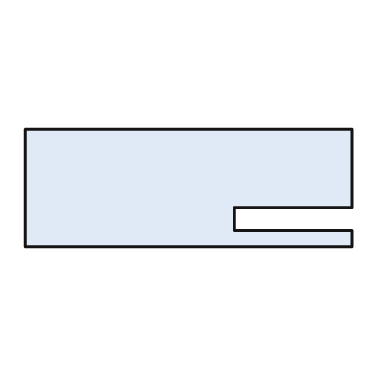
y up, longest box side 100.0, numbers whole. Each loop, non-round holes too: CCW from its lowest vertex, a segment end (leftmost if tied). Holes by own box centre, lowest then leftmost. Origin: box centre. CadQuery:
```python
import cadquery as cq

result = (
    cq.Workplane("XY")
    .moveTo(-50.0, -18.0)
    .lineTo(50.0, -18.0)
    .lineTo(50.0, -13.0)
    .lineTo(14.0, -13.0)
    .lineTo(14.0, -6.0)
    .lineTo(50.0, -6.0)
    .lineTo(50.0, 18.0)
    .lineTo(-50.0, 18.0)
    .close()
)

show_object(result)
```